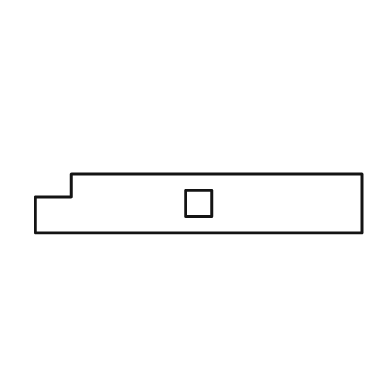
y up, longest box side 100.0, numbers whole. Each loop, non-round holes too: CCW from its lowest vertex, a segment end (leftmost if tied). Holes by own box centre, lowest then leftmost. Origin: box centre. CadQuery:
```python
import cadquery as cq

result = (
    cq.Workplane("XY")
    .moveTo(-50.0, -9.0)
    .lineTo(50.0, -9.0)
    .lineTo(50.0, 9.0)
    .lineTo(-39.0, 9.0)
    .lineTo(-39.0, 2.0)
    .lineTo(-50.0, 2.0)
    .close()
    .moveTo(-4.0, -4.0)
    .lineTo(4.0, -4.0)
    .lineTo(4.0, 4.0)
    .lineTo(-4.0, 4.0)
    .close()
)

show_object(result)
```